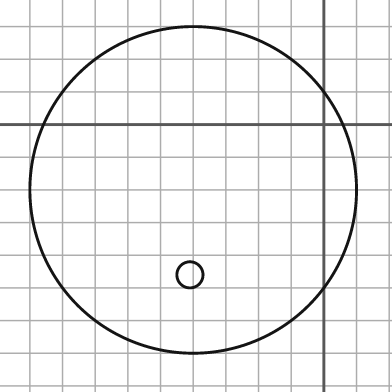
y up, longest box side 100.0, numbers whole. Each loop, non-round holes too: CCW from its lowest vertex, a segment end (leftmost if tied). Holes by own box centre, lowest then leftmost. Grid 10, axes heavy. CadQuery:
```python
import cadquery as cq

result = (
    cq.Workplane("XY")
    .moveTo(-40.0, -20.0)
    .circle(50.0)
    .moveTo(-41.0, -46.0)
    .circle(4.0)
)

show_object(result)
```